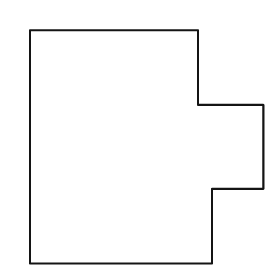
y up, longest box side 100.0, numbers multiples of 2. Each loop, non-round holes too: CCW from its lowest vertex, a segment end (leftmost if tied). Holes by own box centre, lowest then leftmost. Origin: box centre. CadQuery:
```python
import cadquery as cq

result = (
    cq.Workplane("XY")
    .moveTo(-50.0, -50.0)
    .lineTo(28.0, -50.0)
    .lineTo(28.0, -18.0)
    .lineTo(50.0, -18.0)
    .lineTo(50.0, 18.0)
    .lineTo(22.0, 18.0)
    .lineTo(22.0, 50.0)
    .lineTo(-50.0, 50.0)
    .close()
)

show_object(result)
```